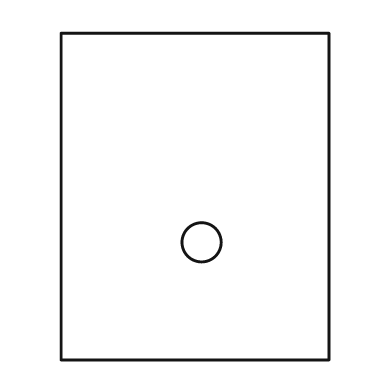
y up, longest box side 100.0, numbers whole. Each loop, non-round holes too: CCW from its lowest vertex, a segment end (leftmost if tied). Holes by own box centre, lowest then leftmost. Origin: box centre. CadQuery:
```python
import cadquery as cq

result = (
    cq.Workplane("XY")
    .moveTo(-41.0, -50.0)
    .lineTo(41.0, -50.0)
    .lineTo(41.0, 50.0)
    .lineTo(-41.0, 50.0)
    .close()
    .moveTo(2.0, -14.0)
    .circle(6.0)
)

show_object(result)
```